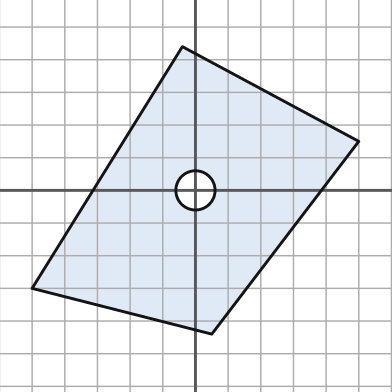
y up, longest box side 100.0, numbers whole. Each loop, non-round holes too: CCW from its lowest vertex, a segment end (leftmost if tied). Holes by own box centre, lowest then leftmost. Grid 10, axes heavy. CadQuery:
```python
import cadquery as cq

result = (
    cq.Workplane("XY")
    .moveTo(5.0, -44.0)
    .lineTo(50.0, 15.0)
    .lineTo(-4.0, 44.0)
    .lineTo(-50.0, -30.0)
    .close()
    .moveTo(0.0, 0.0)
    .circle(6.0)
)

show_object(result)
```